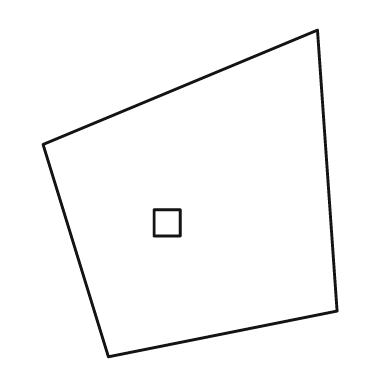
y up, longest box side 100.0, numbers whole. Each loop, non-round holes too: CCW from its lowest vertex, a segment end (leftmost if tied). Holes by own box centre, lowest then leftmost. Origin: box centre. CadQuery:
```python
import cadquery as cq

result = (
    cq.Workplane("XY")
    .moveTo(-25.0, -50.0)
    .lineTo(45.0, -36.0)
    .lineTo(39.0, 50.0)
    .lineTo(-45.0, 15.0)
    .close()
    .moveTo(-11.0, -13.0)
    .lineTo(-3.0, -13.0)
    .lineTo(-3.0, -5.0)
    .lineTo(-11.0, -5.0)
    .close()
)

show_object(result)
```